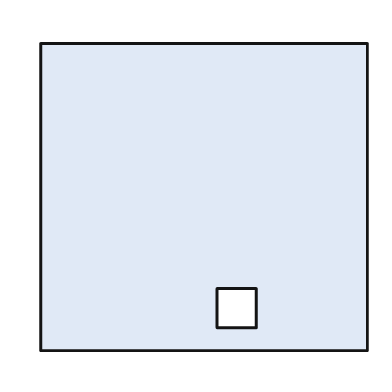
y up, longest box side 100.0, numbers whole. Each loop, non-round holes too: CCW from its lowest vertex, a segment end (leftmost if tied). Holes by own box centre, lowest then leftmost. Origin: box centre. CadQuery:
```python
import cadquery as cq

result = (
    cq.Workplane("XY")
    .moveTo(-50.0, -47.0)
    .lineTo(50.0, -47.0)
    .lineTo(50.0, 47.0)
    .lineTo(-50.0, 47.0)
    .close()
    .moveTo(4.0, -40.0)
    .lineTo(16.0, -40.0)
    .lineTo(16.0, -28.0)
    .lineTo(4.0, -28.0)
    .close()
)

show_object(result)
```